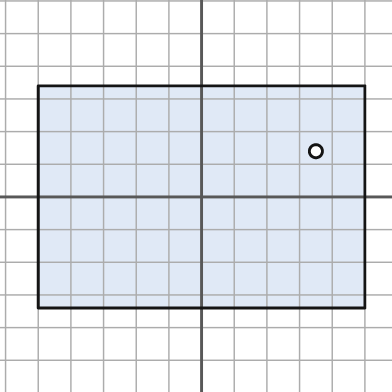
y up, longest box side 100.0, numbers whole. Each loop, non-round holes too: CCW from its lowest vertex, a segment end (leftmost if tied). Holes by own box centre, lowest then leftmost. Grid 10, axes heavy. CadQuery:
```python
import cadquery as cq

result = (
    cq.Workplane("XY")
    .moveTo(-50.0, -34.0)
    .lineTo(50.0, -34.0)
    .lineTo(50.0, 34.0)
    .lineTo(-50.0, 34.0)
    .close()
    .moveTo(35.0, 14.0)
    .circle(2.0)
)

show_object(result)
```